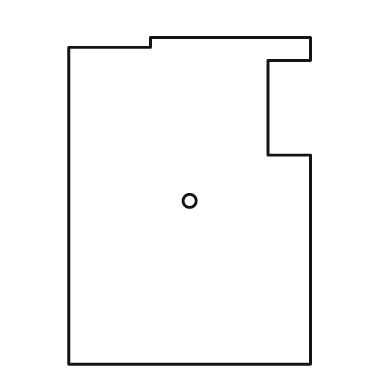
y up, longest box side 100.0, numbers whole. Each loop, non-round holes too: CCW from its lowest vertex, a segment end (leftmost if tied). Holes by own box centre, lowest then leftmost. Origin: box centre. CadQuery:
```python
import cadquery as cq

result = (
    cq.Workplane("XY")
    .moveTo(-37.0, -50.0)
    .lineTo(37.0, -50.0)
    .lineTo(37.0, 14.0)
    .lineTo(24.0, 14.0)
    .lineTo(24.0, 43.0)
    .lineTo(37.0, 43.0)
    .lineTo(37.0, 50.0)
    .lineTo(-12.0, 50.0)
    .lineTo(-12.0, 47.0)
    .lineTo(-37.0, 47.0)
    .close()
    .moveTo(0.0, 0.0)
    .circle(2.0)
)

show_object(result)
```